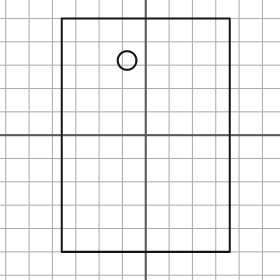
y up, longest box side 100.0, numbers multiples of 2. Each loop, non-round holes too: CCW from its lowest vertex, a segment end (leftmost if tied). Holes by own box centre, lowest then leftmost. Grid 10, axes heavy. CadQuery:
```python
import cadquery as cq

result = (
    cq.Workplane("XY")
    .moveTo(-36.0, -50.0)
    .lineTo(36.0, -50.0)
    .lineTo(36.0, 50.0)
    .lineTo(-36.0, 50.0)
    .close()
    .moveTo(-8.0, 32.0)
    .circle(4.0)
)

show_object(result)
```